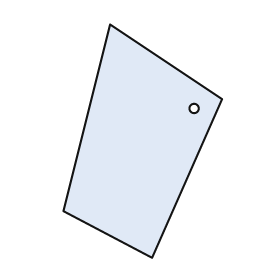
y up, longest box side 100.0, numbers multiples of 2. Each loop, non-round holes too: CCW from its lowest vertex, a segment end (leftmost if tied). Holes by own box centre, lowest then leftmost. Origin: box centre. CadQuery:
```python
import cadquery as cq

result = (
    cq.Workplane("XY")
    .moveTo(4.0, -50.0)
    .lineTo(34.0, 18.0)
    .lineTo(-14.0, 50.0)
    .lineTo(-34.0, -30.0)
    .close()
    .moveTo(22.0, 14.0)
    .circle(2.0)
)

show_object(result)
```